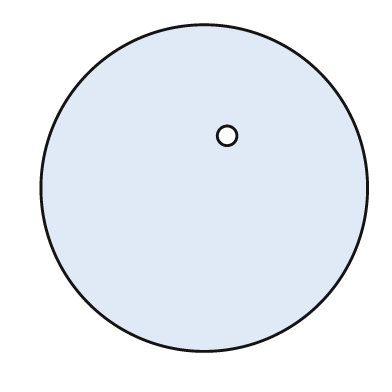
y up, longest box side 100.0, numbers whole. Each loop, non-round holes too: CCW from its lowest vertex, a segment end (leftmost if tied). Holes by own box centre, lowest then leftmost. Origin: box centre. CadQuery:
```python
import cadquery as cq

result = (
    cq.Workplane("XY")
    .moveTo(0.0, 0.0)
    .circle(50.0)
    .moveTo(7.0, 16.0)
    .circle(3.0)
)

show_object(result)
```